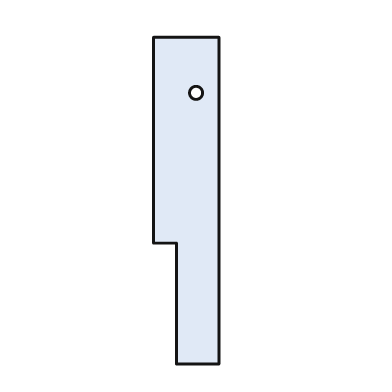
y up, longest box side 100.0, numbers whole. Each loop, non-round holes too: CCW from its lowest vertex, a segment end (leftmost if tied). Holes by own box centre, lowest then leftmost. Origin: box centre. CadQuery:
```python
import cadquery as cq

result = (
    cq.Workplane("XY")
    .moveTo(-3.0, -50.0)
    .lineTo(10.0, -50.0)
    .lineTo(10.0, 50.0)
    .lineTo(-10.0, 50.0)
    .lineTo(-10.0, -13.0)
    .lineTo(-3.0, -13.0)
    .close()
    .moveTo(3.0, 33.0)
    .circle(2.0)
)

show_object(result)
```